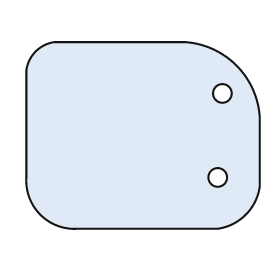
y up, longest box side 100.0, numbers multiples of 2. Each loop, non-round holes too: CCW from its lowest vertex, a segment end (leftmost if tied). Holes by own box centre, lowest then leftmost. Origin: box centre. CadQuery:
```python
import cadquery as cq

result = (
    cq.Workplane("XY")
    .moveTo(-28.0, -40.0)
    .lineTo(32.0, -40.0)
    .threePointArc((44.0, -34.0), (50.0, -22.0))
    .lineTo(50.0, 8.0)
    .threePointArc((40.0, 30.0), (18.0, 40.0))
    .lineTo(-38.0, 40.0)
    .threePointArc((-46.0, 36.0), (-50.0, 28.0))
    .lineTo(-50.0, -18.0)
    .threePointArc((-44.0, -34.0), (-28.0, -40.0))
    .close()
    .moveTo(32.0, -18.0)
    .circle(4.0)
    .moveTo(34.0, 18.0)
    .circle(4.0)
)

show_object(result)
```